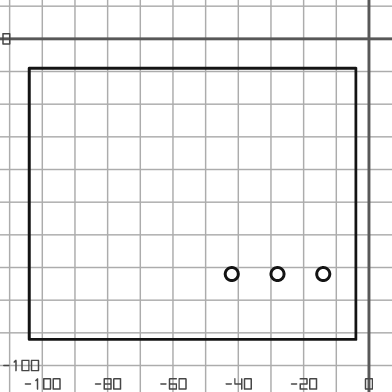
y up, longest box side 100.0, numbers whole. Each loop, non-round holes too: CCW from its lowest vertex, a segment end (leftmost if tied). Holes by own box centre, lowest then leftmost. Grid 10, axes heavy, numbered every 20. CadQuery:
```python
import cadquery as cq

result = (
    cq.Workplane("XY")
    .moveTo(-104.0, -92.0)
    .lineTo(-4.0, -92.0)
    .lineTo(-4.0, -9.0)
    .lineTo(-104.0, -9.0)
    .close()
    .moveTo(-42.0, -72.0)
    .circle(2.0)
    .moveTo(-28.0, -72.0)
    .circle(2.0)
    .moveTo(-14.0, -72.0)
    .circle(2.0)
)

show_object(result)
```